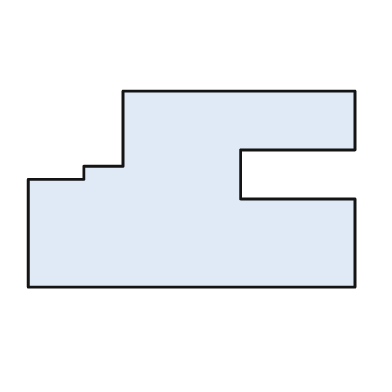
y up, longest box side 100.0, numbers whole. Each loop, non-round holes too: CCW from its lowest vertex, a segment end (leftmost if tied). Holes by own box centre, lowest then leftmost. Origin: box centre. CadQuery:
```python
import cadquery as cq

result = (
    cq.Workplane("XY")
    .moveTo(-50.0, -30.0)
    .lineTo(50.0, -30.0)
    .lineTo(50.0, -3.0)
    .lineTo(15.0, -3.0)
    .lineTo(15.0, 12.0)
    .lineTo(50.0, 12.0)
    .lineTo(50.0, 30.0)
    .lineTo(-21.0, 30.0)
    .lineTo(-21.0, 7.0)
    .lineTo(-33.0, 7.0)
    .lineTo(-33.0, 3.0)
    .lineTo(-50.0, 3.0)
    .close()
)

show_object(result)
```